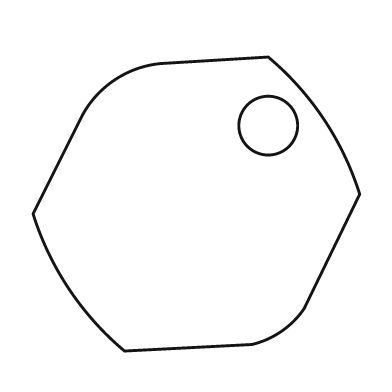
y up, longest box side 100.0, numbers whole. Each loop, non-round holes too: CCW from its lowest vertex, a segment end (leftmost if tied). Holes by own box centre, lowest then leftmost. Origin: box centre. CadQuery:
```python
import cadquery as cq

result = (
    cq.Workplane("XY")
    .moveTo(-22.0, -45.0)
    .lineTo(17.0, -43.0)
    .threePointArc((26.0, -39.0), (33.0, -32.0))
    .lineTo(50.0, 3.0)
    .threePointArc((39.0, 26.0), (22.0, 45.0))
    .lineTo(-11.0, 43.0)
    .threePointArc((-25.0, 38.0), (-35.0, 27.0))
    .lineTo(-50.0, -3.0)
    .threePointArc((-39.0, -26.0), (-22.0, -45.0))
    .close()
    .moveTo(22.0, 24.0)
    .circle(9.0)
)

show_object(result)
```